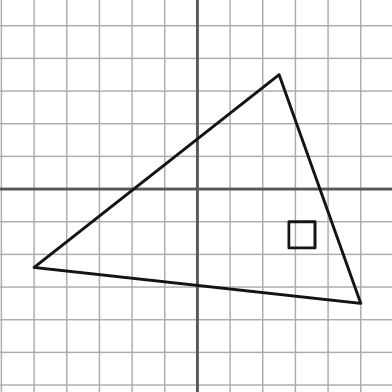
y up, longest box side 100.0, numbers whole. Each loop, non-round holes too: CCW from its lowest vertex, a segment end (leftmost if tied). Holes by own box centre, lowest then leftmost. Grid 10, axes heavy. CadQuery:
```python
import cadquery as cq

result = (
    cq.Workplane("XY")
    .moveTo(50.0, -35.0)
    .lineTo(25.0, 35.0)
    .lineTo(-50.0, -24.0)
    .close()
    .moveTo(28.0, -18.0)
    .lineTo(36.0, -18.0)
    .lineTo(36.0, -10.0)
    .lineTo(28.0, -10.0)
    .close()
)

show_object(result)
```